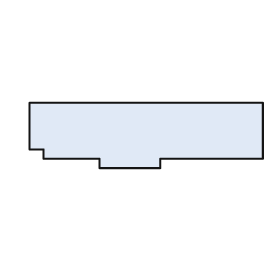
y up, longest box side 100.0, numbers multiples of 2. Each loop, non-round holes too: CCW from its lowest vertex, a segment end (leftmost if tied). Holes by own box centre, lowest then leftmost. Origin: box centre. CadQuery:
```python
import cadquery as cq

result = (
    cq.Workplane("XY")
    .moveTo(-20.0, -14.0)
    .lineTo(6.0, -14.0)
    .lineTo(6.0, -10.0)
    .lineTo(50.0, -10.0)
    .lineTo(50.0, 14.0)
    .lineTo(-50.0, 14.0)
    .lineTo(-50.0, -6.0)
    .lineTo(-44.0, -6.0)
    .lineTo(-44.0, -10.0)
    .lineTo(-20.0, -10.0)
    .close()
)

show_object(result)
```